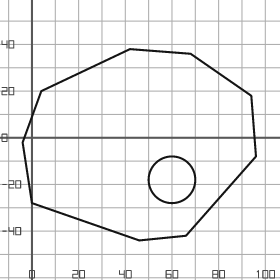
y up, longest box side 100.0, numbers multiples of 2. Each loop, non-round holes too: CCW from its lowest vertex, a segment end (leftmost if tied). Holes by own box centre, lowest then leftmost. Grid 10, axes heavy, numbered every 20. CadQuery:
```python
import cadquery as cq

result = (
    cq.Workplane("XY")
    .moveTo(46.0, -44.0)
    .lineTo(66.0, -42.0)
    .lineTo(96.0, -8.0)
    .lineTo(94.0, 18.0)
    .lineTo(68.0, 36.0)
    .lineTo(42.0, 38.0)
    .lineTo(4.0, 20.0)
    .lineTo(-4.0, -2.0)
    .lineTo(0.0, -28.0)
    .close()
    .moveTo(60.0, -18.0)
    .circle(10.0)
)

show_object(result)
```